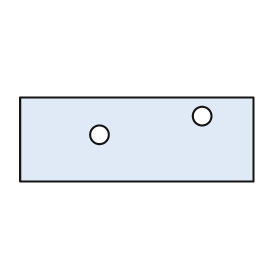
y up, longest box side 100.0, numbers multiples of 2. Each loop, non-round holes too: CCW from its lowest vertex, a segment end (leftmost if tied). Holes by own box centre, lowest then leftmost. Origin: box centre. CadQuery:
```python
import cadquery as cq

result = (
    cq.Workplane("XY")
    .moveTo(-50.0, -18.0)
    .lineTo(50.0, -18.0)
    .lineTo(50.0, 18.0)
    .lineTo(-50.0, 18.0)
    .close()
    .moveTo(-16.0, 2.0)
    .circle(4.0)
    .moveTo(28.0, 10.0)
    .circle(4.0)
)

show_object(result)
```